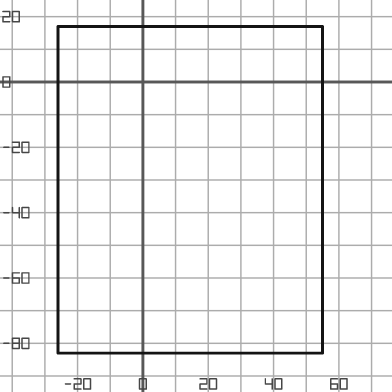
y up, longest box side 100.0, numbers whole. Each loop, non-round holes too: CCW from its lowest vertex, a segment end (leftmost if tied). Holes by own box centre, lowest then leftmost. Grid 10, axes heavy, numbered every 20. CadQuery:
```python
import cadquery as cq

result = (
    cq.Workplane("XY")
    .moveTo(-26.0, -83.0)
    .lineTo(55.0, -83.0)
    .lineTo(55.0, 17.0)
    .lineTo(-26.0, 17.0)
    .close()
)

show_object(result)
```